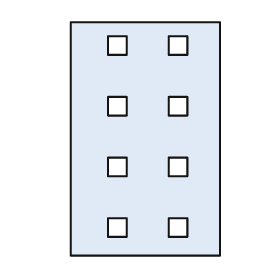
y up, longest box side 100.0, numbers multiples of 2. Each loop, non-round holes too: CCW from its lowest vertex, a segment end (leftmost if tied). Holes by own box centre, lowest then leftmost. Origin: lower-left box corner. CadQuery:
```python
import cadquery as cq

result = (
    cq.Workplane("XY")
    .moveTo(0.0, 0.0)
    .lineTo(64.0, 0.0)
    .lineTo(64.0, 100.0)
    .lineTo(0.0, 100.0)
    .close()
    .moveTo(16.0, 8.0)
    .lineTo(24.0, 8.0)
    .lineTo(24.0, 16.0)
    .lineTo(16.0, 16.0)
    .close()
    .moveTo(42.0, 8.0)
    .lineTo(50.0, 8.0)
    .lineTo(50.0, 16.0)
    .lineTo(42.0, 16.0)
    .close()
    .moveTo(16.0, 34.0)
    .lineTo(24.0, 34.0)
    .lineTo(24.0, 42.0)
    .lineTo(16.0, 42.0)
    .close()
    .moveTo(42.0, 34.0)
    .lineTo(50.0, 34.0)
    .lineTo(50.0, 42.0)
    .lineTo(42.0, 42.0)
    .close()
    .moveTo(16.0, 60.0)
    .lineTo(24.0, 60.0)
    .lineTo(24.0, 68.0)
    .lineTo(16.0, 68.0)
    .close()
    .moveTo(42.0, 60.0)
    .lineTo(50.0, 60.0)
    .lineTo(50.0, 68.0)
    .lineTo(42.0, 68.0)
    .close()
    .moveTo(16.0, 86.0)
    .lineTo(24.0, 86.0)
    .lineTo(24.0, 94.0)
    .lineTo(16.0, 94.0)
    .close()
    .moveTo(42.0, 86.0)
    .lineTo(50.0, 86.0)
    .lineTo(50.0, 94.0)
    .lineTo(42.0, 94.0)
    .close()
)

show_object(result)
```